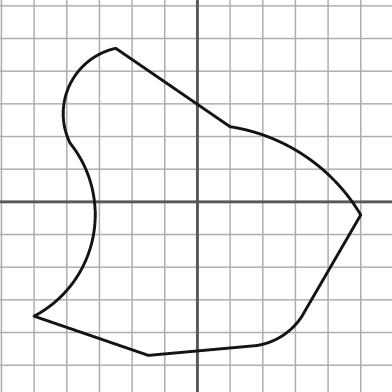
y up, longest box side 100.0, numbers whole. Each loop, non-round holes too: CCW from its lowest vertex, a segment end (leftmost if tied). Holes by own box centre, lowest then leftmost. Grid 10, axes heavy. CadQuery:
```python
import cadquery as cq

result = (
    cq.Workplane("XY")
    .moveTo(-15.0, -47.0)
    .lineTo(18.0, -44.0)
    .threePointArc((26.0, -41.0), (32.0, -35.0))
    .lineTo(50.0, -4.0)
    .threePointArc((33.0, 14.0), (10.0, 23.0))
    .lineTo(-25.0, 47.0)
    .threePointArc((-39.0, 36.0), (-39.0, 18.0))
    .threePointArc((-32.0, -11.0), (-50.0, -35.0))
    .close()
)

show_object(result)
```